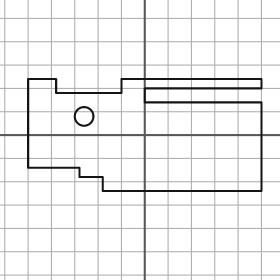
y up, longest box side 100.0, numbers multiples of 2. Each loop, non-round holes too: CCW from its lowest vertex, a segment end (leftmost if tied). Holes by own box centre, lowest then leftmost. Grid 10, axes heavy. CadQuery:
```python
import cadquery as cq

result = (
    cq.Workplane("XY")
    .moveTo(-18.0, -24.0)
    .lineTo(50.0, -24.0)
    .lineTo(50.0, 14.0)
    .lineTo(0.0, 14.0)
    .lineTo(0.0, 20.0)
    .lineTo(50.0, 20.0)
    .lineTo(50.0, 24.0)
    .lineTo(-10.0, 24.0)
    .lineTo(-10.0, 18.0)
    .lineTo(-38.0, 18.0)
    .lineTo(-38.0, 24.0)
    .lineTo(-50.0, 24.0)
    .lineTo(-50.0, -14.0)
    .lineTo(-28.0, -14.0)
    .lineTo(-28.0, -18.0)
    .lineTo(-18.0, -18.0)
    .close()
    .moveTo(-26.0, 8.0)
    .circle(4.0)
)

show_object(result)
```